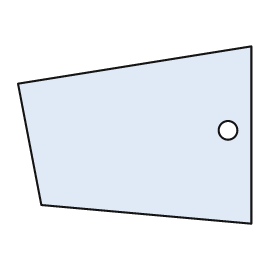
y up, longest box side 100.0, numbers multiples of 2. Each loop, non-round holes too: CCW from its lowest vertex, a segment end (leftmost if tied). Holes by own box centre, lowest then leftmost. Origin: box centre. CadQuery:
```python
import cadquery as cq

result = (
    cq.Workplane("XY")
    .moveTo(50.0, -38.0)
    .lineTo(50.0, 38.0)
    .lineTo(-50.0, 22.0)
    .lineTo(-40.0, -30.0)
    .close()
    .moveTo(40.0, 2.0)
    .circle(4.0)
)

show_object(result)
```